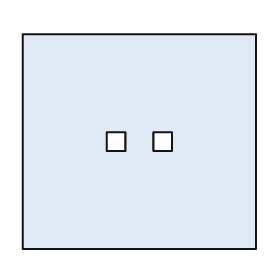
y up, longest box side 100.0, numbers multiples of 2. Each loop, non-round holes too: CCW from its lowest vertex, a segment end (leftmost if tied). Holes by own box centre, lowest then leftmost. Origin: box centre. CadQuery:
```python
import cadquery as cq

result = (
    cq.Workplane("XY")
    .moveTo(-50.0, -46.0)
    .lineTo(50.0, -46.0)
    .lineTo(50.0, 46.0)
    .lineTo(-50.0, 46.0)
    .close()
    .moveTo(-14.0, -4.0)
    .lineTo(-6.0, -4.0)
    .lineTo(-6.0, 4.0)
    .lineTo(-14.0, 4.0)
    .close()
    .moveTo(6.0, -4.0)
    .lineTo(14.0, -4.0)
    .lineTo(14.0, 4.0)
    .lineTo(6.0, 4.0)
    .close()
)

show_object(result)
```